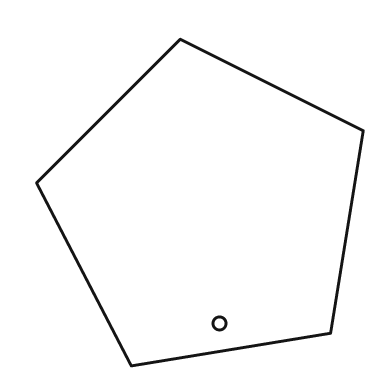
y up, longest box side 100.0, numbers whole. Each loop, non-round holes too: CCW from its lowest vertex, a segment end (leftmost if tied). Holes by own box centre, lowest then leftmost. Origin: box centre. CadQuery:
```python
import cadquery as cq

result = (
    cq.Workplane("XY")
    .moveTo(-21.0, -50.0)
    .lineTo(40.0, -40.0)
    .lineTo(50.0, 22.0)
    .lineTo(-6.0, 50.0)
    .lineTo(-50.0, 6.0)
    .close()
    .moveTo(6.0, -37.0)
    .circle(2.0)
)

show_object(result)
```